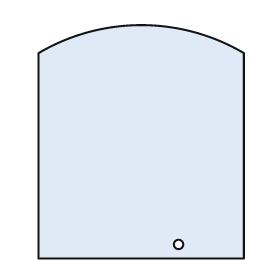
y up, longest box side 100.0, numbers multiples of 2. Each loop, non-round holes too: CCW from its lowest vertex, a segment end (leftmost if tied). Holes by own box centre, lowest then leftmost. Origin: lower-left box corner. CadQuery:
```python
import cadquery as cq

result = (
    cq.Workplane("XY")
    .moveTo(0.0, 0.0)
    .lineTo(88.0, 0.0)
    .lineTo(88.0, 88.0)
    .threePointArc((44.0, 100.0), (0.0, 88.0))
    .close()
    .moveTo(60.0, 6.0)
    .circle(2.0)
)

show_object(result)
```